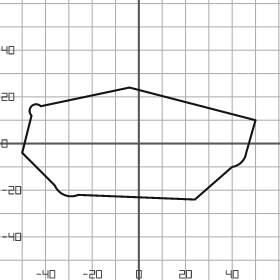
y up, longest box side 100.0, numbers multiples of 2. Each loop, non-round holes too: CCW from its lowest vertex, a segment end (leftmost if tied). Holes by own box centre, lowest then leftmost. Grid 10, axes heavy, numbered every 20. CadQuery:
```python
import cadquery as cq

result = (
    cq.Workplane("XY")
    .moveTo(24.0, -24.0)
    .lineTo(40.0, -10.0)
    .threePointArc((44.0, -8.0), (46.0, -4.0))
    .lineTo(50.0, 10.0)
    .lineTo(-4.0, 24.0)
    .lineTo(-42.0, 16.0)
    .threePointArc((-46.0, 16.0), (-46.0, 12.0))
    .lineTo(-50.0, -4.0)
    .lineTo(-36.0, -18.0)
    .threePointArc((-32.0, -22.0), (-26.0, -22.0))
    .close()
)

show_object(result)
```